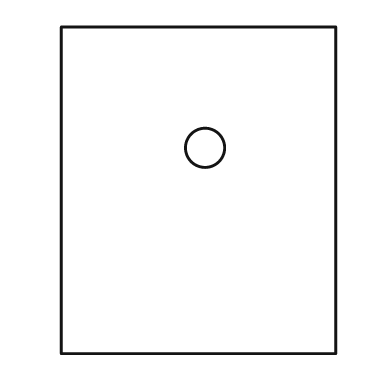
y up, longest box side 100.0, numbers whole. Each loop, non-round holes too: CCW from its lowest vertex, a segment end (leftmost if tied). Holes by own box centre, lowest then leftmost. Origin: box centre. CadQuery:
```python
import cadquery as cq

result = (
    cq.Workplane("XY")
    .moveTo(-42.0, -50.0)
    .lineTo(42.0, -50.0)
    .lineTo(42.0, 50.0)
    .lineTo(-42.0, 50.0)
    .close()
    .moveTo(2.0, 13.0)
    .circle(6.0)
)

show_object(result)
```